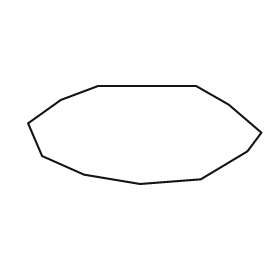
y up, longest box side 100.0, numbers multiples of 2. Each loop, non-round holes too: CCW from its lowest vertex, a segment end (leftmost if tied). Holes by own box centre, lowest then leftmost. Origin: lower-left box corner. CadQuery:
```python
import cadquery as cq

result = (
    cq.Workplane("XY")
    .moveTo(48.0, 0.0)
    .lineTo(74.0, 2.0)
    .lineTo(94.0, 14.0)
    .lineTo(100.0, 22.0)
    .lineTo(86.0, 34.0)
    .lineTo(72.0, 42.0)
    .lineTo(30.0, 42.0)
    .lineTo(14.0, 36.0)
    .lineTo(0.0, 26.0)
    .lineTo(6.0, 12.0)
    .lineTo(24.0, 4.0)
    .close()
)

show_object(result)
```